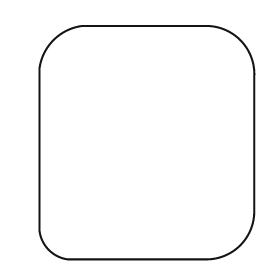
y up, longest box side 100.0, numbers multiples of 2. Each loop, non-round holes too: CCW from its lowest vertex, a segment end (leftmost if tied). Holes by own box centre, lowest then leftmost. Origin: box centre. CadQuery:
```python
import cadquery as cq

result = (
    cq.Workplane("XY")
    .moveTo(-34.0, -50.0)
    .lineTo(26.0, -50.0)
    .threePointArc((40.0, -44.0), (46.0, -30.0))
    .lineTo(46.0, 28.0)
    .threePointArc((40.0, 44.0), (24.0, 50.0))
    .lineTo(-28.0, 50.0)
    .threePointArc((-40.0, 44.0), (-46.0, 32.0))
    .lineTo(-46.0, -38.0)
    .threePointArc((-42.0, -46.0), (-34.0, -50.0))
    .close()
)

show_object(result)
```